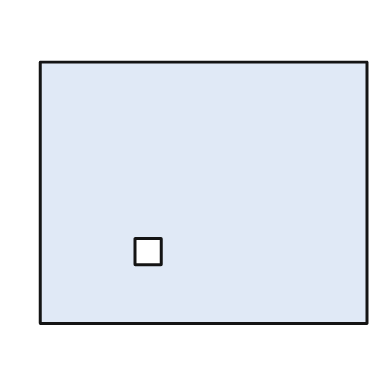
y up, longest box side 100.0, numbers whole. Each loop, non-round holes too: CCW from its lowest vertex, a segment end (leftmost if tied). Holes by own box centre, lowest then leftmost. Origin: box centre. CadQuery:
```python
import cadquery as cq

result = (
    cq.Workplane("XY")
    .moveTo(-50.0, -40.0)
    .lineTo(50.0, -40.0)
    .lineTo(50.0, 40.0)
    .lineTo(-50.0, 40.0)
    .close()
    .moveTo(-21.0, -22.0)
    .lineTo(-13.0, -22.0)
    .lineTo(-13.0, -14.0)
    .lineTo(-21.0, -14.0)
    .close()
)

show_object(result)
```